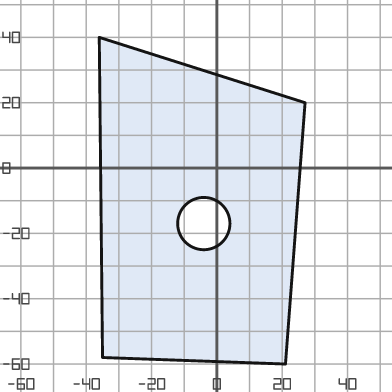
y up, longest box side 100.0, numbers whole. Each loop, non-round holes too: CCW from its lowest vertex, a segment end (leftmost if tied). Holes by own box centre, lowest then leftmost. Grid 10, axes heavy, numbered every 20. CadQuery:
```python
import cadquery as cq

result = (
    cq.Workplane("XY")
    .moveTo(21.0, -60.0)
    .lineTo(27.0, 20.0)
    .lineTo(-36.0, 40.0)
    .lineTo(-35.0, -58.0)
    .close()
    .moveTo(-4.0, -17.0)
    .circle(8.0)
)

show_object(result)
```